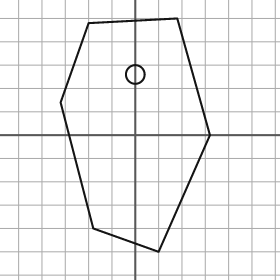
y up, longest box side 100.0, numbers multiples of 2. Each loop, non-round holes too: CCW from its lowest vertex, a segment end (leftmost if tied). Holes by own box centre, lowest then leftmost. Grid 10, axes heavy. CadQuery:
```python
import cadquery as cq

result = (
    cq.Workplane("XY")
    .moveTo(10.0, -50.0)
    .lineTo(32.0, 0.0)
    .lineTo(18.0, 50.0)
    .lineTo(-20.0, 48.0)
    .lineTo(-32.0, 14.0)
    .lineTo(-18.0, -40.0)
    .close()
    .moveTo(0.0, 26.0)
    .circle(4.0)
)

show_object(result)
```